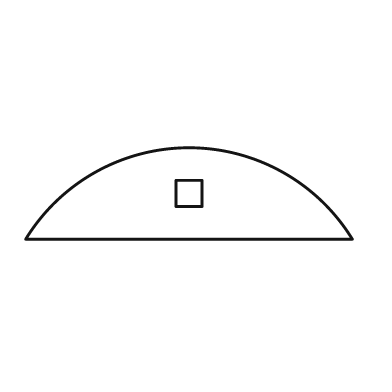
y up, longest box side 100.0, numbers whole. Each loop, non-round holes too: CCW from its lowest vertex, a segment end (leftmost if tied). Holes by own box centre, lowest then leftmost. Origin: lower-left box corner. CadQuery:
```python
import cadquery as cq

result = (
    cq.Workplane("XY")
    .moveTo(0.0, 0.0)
    .lineTo(100.0, 0.0)
    .threePointArc((50.0, 28.0), (0.0, 0.0))
    .close()
    .moveTo(46.0, 10.0)
    .lineTo(54.0, 10.0)
    .lineTo(54.0, 18.0)
    .lineTo(46.0, 18.0)
    .close()
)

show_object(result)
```